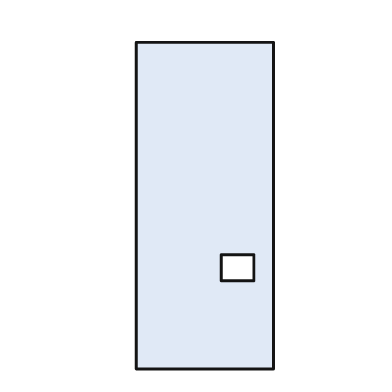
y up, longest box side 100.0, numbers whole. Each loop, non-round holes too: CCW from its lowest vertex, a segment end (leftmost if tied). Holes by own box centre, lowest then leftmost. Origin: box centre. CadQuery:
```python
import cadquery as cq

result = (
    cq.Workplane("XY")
    .moveTo(-21.0, -50.0)
    .lineTo(21.0, -50.0)
    .lineTo(21.0, 50.0)
    .lineTo(-21.0, 50.0)
    .close()
    .moveTo(5.0, -23.0)
    .lineTo(15.0, -23.0)
    .lineTo(15.0, -15.0)
    .lineTo(5.0, -15.0)
    .close()
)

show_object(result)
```